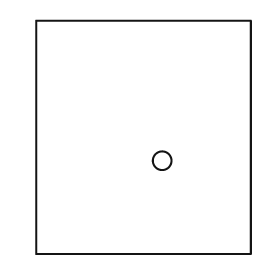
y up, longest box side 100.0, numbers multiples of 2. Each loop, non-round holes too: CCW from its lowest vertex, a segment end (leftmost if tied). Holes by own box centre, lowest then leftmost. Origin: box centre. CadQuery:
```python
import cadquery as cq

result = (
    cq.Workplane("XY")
    .moveTo(-46.0, -50.0)
    .lineTo(46.0, -50.0)
    .lineTo(46.0, 50.0)
    .lineTo(-46.0, 50.0)
    .close()
    .moveTo(8.0, -10.0)
    .circle(4.0)
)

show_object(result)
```